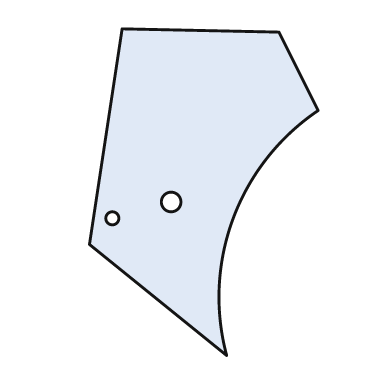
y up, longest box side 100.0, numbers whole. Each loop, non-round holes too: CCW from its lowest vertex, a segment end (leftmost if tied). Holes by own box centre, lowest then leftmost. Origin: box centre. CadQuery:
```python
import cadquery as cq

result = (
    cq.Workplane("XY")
    .moveTo(7.0, -50.0)
    .threePointArc((9.0, -8.0), (35.0, 25.0))
    .lineTo(23.0, 49.0)
    .lineTo(-25.0, 50.0)
    .lineTo(-35.0, -16.0)
    .close()
    .moveTo(-28.0, -8.0)
    .circle(2.0)
    .moveTo(-10.0, -3.0)
    .circle(3.0)
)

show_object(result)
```